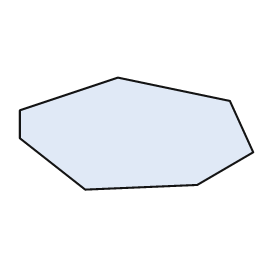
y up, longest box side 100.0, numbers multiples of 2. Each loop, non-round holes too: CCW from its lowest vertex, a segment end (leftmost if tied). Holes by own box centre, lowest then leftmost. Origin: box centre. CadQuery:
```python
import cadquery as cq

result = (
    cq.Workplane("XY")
    .moveTo(-22.0, -24.0)
    .lineTo(26.0, -22.0)
    .lineTo(50.0, -8.0)
    .lineTo(40.0, 14.0)
    .lineTo(-8.0, 24.0)
    .lineTo(-50.0, 10.0)
    .lineTo(-50.0, -2.0)
    .close()
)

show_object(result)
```